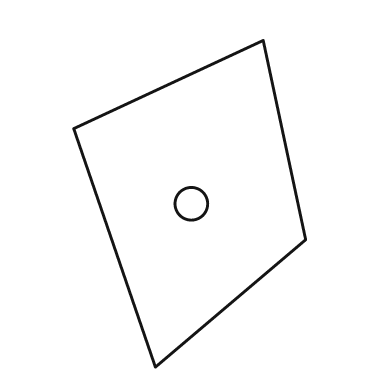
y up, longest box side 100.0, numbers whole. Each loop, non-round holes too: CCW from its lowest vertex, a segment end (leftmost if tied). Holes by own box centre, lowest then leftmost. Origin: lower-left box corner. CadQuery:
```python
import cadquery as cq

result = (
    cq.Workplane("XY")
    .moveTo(25.0, 0.0)
    .lineTo(71.0, 39.0)
    .lineTo(58.0, 100.0)
    .lineTo(0.0, 73.0)
    .close()
    .moveTo(36.0, 50.0)
    .circle(5.0)
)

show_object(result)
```